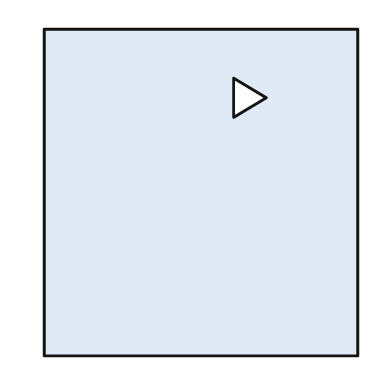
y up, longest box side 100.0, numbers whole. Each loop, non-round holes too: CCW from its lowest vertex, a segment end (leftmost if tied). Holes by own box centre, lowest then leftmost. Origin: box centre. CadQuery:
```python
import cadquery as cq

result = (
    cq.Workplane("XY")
    .moveTo(-48.0, -50.0)
    .lineTo(48.0, -50.0)
    .lineTo(48.0, 50.0)
    .lineTo(-48.0, 50.0)
    .close()
    .moveTo(10.0, 23.0)
    .lineTo(20.0, 29.0)
    .lineTo(10.0, 35.0)
    .close()
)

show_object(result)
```